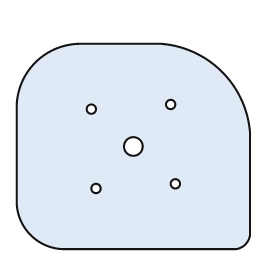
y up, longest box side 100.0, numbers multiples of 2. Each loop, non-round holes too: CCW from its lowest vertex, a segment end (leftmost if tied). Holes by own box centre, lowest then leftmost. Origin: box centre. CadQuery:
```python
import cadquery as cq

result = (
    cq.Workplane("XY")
    .moveTo(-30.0, -44.0)
    .lineTo(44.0, -44.0)
    .threePointArc((48.0, -42.0), (50.0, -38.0))
    .lineTo(50.0, 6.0)
    .threePointArc((38.0, 32.0), (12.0, 44.0))
    .lineTo(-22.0, 44.0)
    .threePointArc((-42.0, 36.0), (-50.0, 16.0))
    .lineTo(-50.0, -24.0)
    .threePointArc((-44.0, -38.0), (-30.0, -44.0))
    .close()
    .moveTo(-16.0, -18.0)
    .circle(2.0)
    .moveTo(18.0, -16.0)
    .circle(2.0)
    .moveTo(0.0, 0.0)
    .circle(4.0)
    .moveTo(-18.0, 16.0)
    .circle(2.0)
    .moveTo(16.0, 18.0)
    .circle(2.0)
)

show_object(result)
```